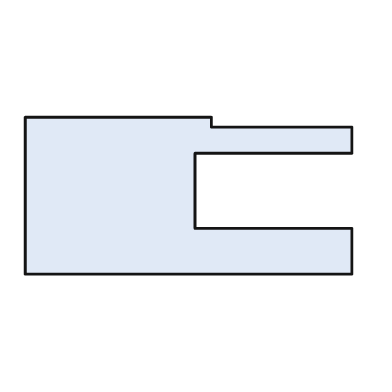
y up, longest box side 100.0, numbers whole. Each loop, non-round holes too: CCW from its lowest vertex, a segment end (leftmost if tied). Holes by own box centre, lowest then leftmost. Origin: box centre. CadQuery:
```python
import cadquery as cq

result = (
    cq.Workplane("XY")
    .moveTo(-50.0, -24.0)
    .lineTo(50.0, -24.0)
    .lineTo(50.0, -10.0)
    .lineTo(2.0, -10.0)
    .lineTo(2.0, 13.0)
    .lineTo(50.0, 13.0)
    .lineTo(50.0, 21.0)
    .lineTo(7.0, 21.0)
    .lineTo(7.0, 24.0)
    .lineTo(-50.0, 24.0)
    .close()
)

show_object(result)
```